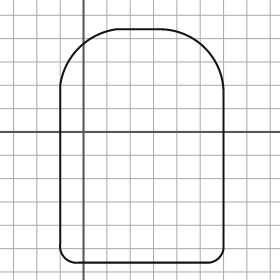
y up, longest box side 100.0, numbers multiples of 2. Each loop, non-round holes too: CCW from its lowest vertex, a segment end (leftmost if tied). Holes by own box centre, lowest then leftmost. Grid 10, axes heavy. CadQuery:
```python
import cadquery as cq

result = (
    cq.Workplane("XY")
    .moveTo(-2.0, -56.0)
    .lineTo(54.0, -56.0)
    .threePointArc((58.0, -54.0), (60.0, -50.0))
    .lineTo(60.0, 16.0)
    .threePointArc((52.0, 36.0), (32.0, 44.0))
    .lineTo(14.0, 44.0)
    .threePointArc((-2.0, 36.0), (-10.0, 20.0))
    .lineTo(-10.0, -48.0)
    .threePointArc((-8.0, -54.0), (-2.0, -56.0))
    .close()
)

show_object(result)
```